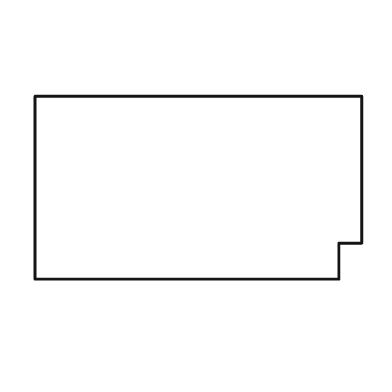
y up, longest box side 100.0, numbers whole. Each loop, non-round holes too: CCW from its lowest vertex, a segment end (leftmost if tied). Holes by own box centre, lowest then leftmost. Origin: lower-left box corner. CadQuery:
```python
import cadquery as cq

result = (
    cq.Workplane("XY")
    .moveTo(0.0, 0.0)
    .lineTo(93.0, 0.0)
    .lineTo(93.0, 11.0)
    .lineTo(100.0, 11.0)
    .lineTo(100.0, 56.0)
    .lineTo(0.0, 56.0)
    .close()
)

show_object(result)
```